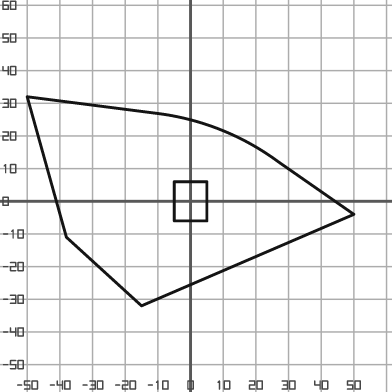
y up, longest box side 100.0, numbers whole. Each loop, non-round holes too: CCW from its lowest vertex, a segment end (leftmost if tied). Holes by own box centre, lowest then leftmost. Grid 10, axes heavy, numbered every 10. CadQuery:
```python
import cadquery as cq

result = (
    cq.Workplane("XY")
    .moveTo(-15.0, -32.0)
    .lineTo(50.0, -4.0)
    .lineTo(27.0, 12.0)
    .threePointArc((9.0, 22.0), (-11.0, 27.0))
    .lineTo(-50.0, 32.0)
    .lineTo(-38.0, -11.0)
    .close()
    .moveTo(-5.0, -6.0)
    .lineTo(5.0, -6.0)
    .lineTo(5.0, 6.0)
    .lineTo(-5.0, 6.0)
    .close()
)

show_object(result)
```